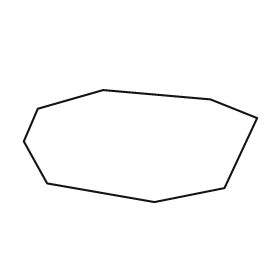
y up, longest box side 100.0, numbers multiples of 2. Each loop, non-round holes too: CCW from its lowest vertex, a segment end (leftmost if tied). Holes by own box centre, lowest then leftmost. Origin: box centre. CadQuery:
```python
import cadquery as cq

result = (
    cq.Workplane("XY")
    .moveTo(6.0, -24.0)
    .lineTo(36.0, -18.0)
    .lineTo(50.0, 12.0)
    .lineTo(30.0, 20.0)
    .lineTo(-16.0, 24.0)
    .lineTo(-44.0, 16.0)
    .lineTo(-50.0, 2.0)
    .lineTo(-40.0, -16.0)
    .close()
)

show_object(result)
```